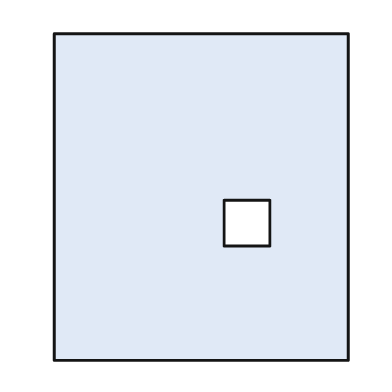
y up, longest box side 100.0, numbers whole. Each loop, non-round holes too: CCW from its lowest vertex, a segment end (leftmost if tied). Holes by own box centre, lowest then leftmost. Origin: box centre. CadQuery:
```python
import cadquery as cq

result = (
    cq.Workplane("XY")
    .moveTo(-45.0, -50.0)
    .lineTo(45.0, -50.0)
    .lineTo(45.0, 50.0)
    .lineTo(-45.0, 50.0)
    .close()
    .moveTo(7.0, -15.0)
    .lineTo(21.0, -15.0)
    .lineTo(21.0, -1.0)
    .lineTo(7.0, -1.0)
    .close()
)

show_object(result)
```